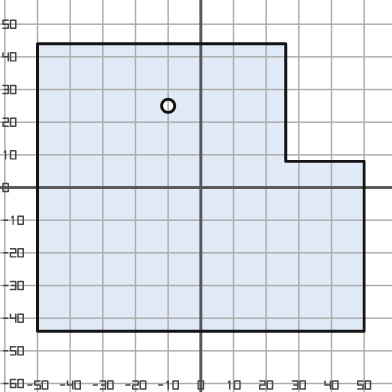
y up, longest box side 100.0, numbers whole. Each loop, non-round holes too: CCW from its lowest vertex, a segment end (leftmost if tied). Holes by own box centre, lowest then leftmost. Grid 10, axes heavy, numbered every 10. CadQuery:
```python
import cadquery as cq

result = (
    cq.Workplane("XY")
    .moveTo(-50.0, -44.0)
    .lineTo(50.0, -44.0)
    .lineTo(50.0, 8.0)
    .lineTo(26.0, 8.0)
    .lineTo(26.0, 44.0)
    .lineTo(-50.0, 44.0)
    .close()
    .moveTo(-10.0, 25.0)
    .circle(2.0)
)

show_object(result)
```